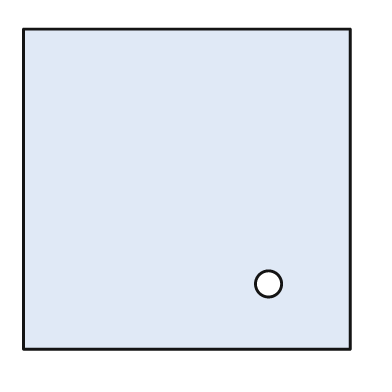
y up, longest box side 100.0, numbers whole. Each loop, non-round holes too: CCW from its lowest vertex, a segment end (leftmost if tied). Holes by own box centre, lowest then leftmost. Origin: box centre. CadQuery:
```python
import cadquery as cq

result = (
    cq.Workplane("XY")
    .moveTo(-50.0, -49.0)
    .lineTo(50.0, -49.0)
    .lineTo(50.0, 49.0)
    .lineTo(-50.0, 49.0)
    .close()
    .moveTo(25.0, -29.0)
    .circle(4.0)
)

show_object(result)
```